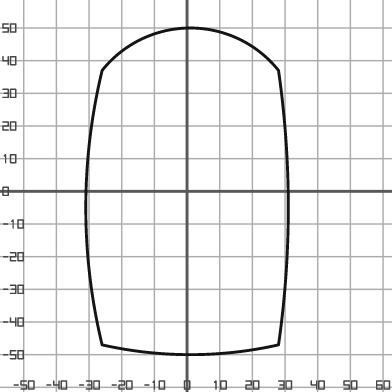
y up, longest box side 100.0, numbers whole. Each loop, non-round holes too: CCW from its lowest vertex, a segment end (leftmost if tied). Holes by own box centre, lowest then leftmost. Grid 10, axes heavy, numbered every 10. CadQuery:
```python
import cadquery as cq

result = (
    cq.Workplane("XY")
    .moveTo(-26.0, -47.0)
    .threePointArc((1.0, -50.0), (28.0, -47.0))
    .threePointArc((31.0, -5.0), (28.0, 37.0))
    .threePointArc((1.0, 50.0), (-26.0, 37.0))
    .threePointArc((-31.0, -5.0), (-26.0, -47.0))
    .close()
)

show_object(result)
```